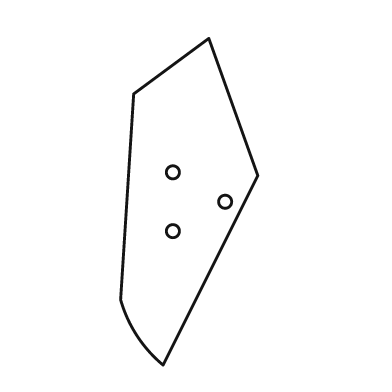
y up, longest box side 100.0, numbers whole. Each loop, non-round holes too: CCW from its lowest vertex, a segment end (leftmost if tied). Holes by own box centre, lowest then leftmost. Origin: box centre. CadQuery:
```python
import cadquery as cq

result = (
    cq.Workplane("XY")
    .moveTo(-8.0, -50.0)
    .lineTo(21.0, 8.0)
    .lineTo(6.0, 50.0)
    .lineTo(-17.0, 33.0)
    .lineTo(-21.0, -30.0)
    .threePointArc((-16.0, -41.0), (-8.0, -50.0))
    .close()
    .moveTo(-5.0, -9.0)
    .circle(2.0)
    .moveTo(11.0, 0.0)
    .circle(2.0)
    .moveTo(-5.0, 9.0)
    .circle(2.0)
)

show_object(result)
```